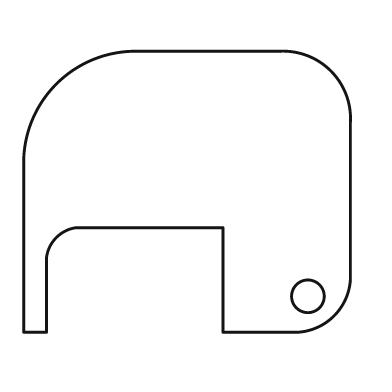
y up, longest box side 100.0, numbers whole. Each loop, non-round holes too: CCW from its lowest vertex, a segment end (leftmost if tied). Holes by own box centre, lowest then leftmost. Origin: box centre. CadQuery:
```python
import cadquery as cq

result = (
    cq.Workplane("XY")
    .moveTo(-50.0, -43.0)
    .lineTo(-43.0, -43.0)
    .lineTo(-43.0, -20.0)
    .threePointArc((-40.0, -14.0), (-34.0, -11.0))
    .lineTo(11.0, -11.0)
    .lineTo(11.0, -43.0)
    .lineTo(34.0, -43.0)
    .threePointArc((45.0, -38.0), (50.0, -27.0))
    .lineTo(50.0, 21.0)
    .threePointArc((44.0, 37.0), (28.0, 43.0))
    .lineTo(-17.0, 43.0)
    .threePointArc((-40.0, 33.0), (-50.0, 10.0))
    .close()
    .moveTo(37.0, -32.0)
    .circle(5.0)
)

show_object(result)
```